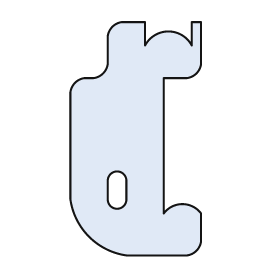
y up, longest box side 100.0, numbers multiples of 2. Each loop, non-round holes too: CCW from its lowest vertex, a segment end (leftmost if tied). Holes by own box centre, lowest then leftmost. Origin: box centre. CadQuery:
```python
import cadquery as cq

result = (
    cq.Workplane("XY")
    .moveTo(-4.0, -50.0)
    .lineTo(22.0, -50.0)
    .threePointArc((26.0, -48.0), (28.0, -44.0))
    .lineTo(28.0, -32.0)
    .threePointArc((20.0, -28.0), (12.0, -32.0))
    .lineTo(12.0, 26.0)
    .lineTo(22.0, 26.0)
    .threePointArc((26.0, 28.0), (28.0, 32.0))
    .lineTo(28.0, 50.0)
    .lineTo(24.0, 50.0)
    .lineTo(24.0, 40.0)
    .threePointArc((14.0, 46.0), (4.0, 40.0))
    .lineTo(4.0, 50.0)
    .lineTo(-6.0, 50.0)
    .threePointArc((-10.0, 48.0), (-12.0, 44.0))
    .lineTo(-12.0, 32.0)
    .threePointArc((-14.0, 28.0), (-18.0, 26.0))
    .lineTo(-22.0, 26.0)
    .threePointArc((-26.0, 24.0), (-28.0, 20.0))
    .lineTo(-28.0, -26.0)
    .threePointArc((-20.0, -42.0), (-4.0, -50.0))
    .close()
    .moveTo(-12.0, -26.0)
    .threePointArc((-8.0, -30.0), (-4.0, -26.0))
    .lineTo(-4.0, -18.0)
    .threePointArc((-8.0, -14.0), (-12.0, -18.0))
    .close()
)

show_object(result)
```